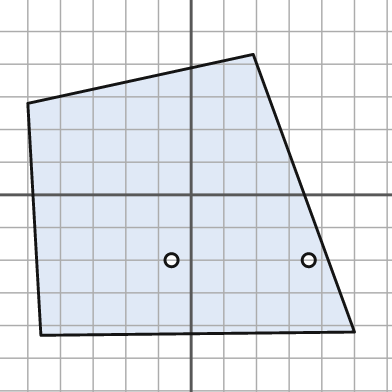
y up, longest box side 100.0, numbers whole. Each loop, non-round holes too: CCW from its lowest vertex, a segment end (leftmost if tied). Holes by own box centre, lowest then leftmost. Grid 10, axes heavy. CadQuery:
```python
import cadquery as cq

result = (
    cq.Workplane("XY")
    .moveTo(-46.0, -43.0)
    .lineTo(50.0, -42.0)
    .lineTo(19.0, 43.0)
    .lineTo(-50.0, 28.0)
    .close()
    .moveTo(-6.0, -20.0)
    .circle(2.0)
    .moveTo(36.0, -20.0)
    .circle(2.0)
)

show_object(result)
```